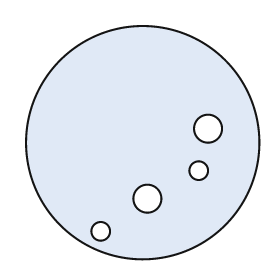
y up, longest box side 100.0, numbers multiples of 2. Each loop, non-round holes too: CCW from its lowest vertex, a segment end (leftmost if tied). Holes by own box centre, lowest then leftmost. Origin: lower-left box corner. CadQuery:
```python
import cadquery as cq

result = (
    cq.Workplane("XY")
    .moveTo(50.0, 50.0)
    .circle(50.0)
    .moveTo(32.0, 12.0)
    .circle(4.0)
    .moveTo(52.0, 26.0)
    .circle(6.0)
    .moveTo(74.0, 38.0)
    .circle(4.0)
    .moveTo(78.0, 56.0)
    .circle(6.0)
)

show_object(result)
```